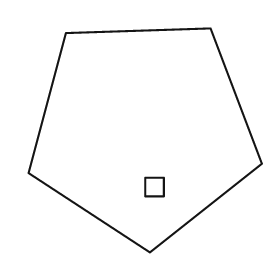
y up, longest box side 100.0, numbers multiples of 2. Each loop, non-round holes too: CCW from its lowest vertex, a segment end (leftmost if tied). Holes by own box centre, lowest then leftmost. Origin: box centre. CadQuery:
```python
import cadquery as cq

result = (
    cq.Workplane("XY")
    .moveTo(2.0, -48.0)
    .lineTo(50.0, -10.0)
    .lineTo(28.0, 48.0)
    .lineTo(-34.0, 46.0)
    .lineTo(-50.0, -14.0)
    .close()
    .moveTo(0.0, -24.0)
    .lineTo(8.0, -24.0)
    .lineTo(8.0, -16.0)
    .lineTo(0.0, -16.0)
    .close()
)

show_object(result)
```